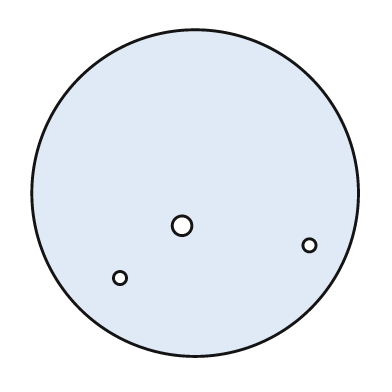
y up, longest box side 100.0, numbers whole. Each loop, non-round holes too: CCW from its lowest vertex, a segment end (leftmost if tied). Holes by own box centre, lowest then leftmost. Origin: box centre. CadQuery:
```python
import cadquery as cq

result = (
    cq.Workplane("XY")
    .moveTo(0.0, 0.0)
    .circle(50.0)
    .moveTo(-23.0, -26.0)
    .circle(2.0)
    .moveTo(35.0, -16.0)
    .circle(2.0)
    .moveTo(-4.0, -10.0)
    .circle(3.0)
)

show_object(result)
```